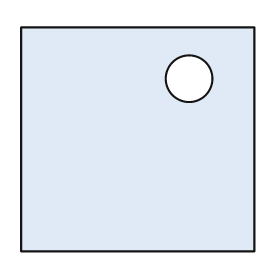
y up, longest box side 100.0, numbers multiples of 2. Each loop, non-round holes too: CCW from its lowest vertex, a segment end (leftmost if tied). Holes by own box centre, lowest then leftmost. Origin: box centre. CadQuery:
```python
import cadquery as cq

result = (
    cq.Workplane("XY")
    .moveTo(-50.0, -48.0)
    .lineTo(50.0, -48.0)
    .lineTo(50.0, 48.0)
    .lineTo(-50.0, 48.0)
    .close()
    .moveTo(22.0, 26.0)
    .circle(10.0)
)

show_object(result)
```